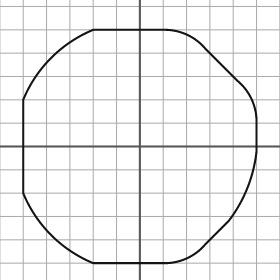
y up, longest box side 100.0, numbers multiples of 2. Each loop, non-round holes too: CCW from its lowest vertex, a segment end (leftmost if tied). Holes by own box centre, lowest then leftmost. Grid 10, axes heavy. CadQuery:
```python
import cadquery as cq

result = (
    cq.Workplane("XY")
    .moveTo(-20.0, -50.0)
    .lineTo(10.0, -50.0)
    .threePointArc((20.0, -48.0), (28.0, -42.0))
    .lineTo(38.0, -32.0)
    .threePointArc((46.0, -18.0), (50.0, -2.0))
    .lineTo(50.0, 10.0)
    .threePointArc((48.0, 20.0), (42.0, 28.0))
    .lineTo(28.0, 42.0)
    .threePointArc((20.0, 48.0), (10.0, 50.0))
    .lineTo(-20.0, 50.0)
    .threePointArc((-38.0, 38.0), (-50.0, 20.0))
    .lineTo(-50.0, -20.0)
    .threePointArc((-38.0, -38.0), (-20.0, -50.0))
    .close()
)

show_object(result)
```